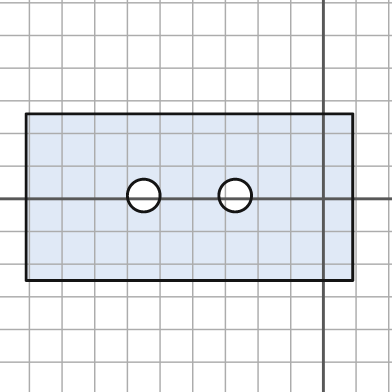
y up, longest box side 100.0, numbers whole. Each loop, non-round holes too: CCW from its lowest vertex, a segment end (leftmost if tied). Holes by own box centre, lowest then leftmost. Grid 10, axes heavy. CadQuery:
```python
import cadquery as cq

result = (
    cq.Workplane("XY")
    .moveTo(-91.0, -25.0)
    .lineTo(9.0, -25.0)
    .lineTo(9.0, 26.0)
    .lineTo(-91.0, 26.0)
    .close()
    .moveTo(-55.0, 1.0)
    .circle(5.0)
    .moveTo(-27.0, 1.0)
    .circle(5.0)
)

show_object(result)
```